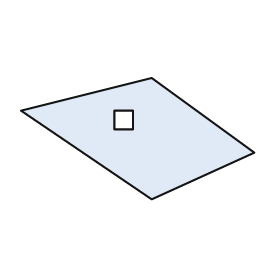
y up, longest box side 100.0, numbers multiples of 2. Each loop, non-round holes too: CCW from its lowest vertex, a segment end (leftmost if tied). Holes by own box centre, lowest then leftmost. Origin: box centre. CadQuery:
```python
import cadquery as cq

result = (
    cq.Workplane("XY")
    .moveTo(6.0, -26.0)
    .lineTo(50.0, -6.0)
    .lineTo(6.0, 26.0)
    .lineTo(-50.0, 12.0)
    .close()
    .moveTo(-10.0, 4.0)
    .lineTo(-2.0, 4.0)
    .lineTo(-2.0, 12.0)
    .lineTo(-10.0, 12.0)
    .close()
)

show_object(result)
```